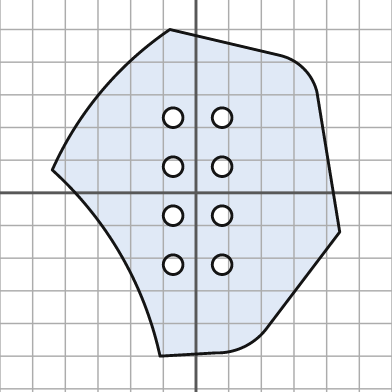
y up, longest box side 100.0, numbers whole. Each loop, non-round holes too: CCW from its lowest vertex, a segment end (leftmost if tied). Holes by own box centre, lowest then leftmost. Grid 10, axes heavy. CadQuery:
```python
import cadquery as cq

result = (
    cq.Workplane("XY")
    .moveTo(-11.0, -50.0)
    .lineTo(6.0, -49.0)
    .threePointArc((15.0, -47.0), (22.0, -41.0))
    .lineTo(44.0, -12.0)
    .lineTo(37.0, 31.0)
    .threePointArc((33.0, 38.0), (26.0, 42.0))
    .lineTo(-8.0, 50.0)
    .threePointArc((-29.0, 31.0), (-44.0, 7.0))
    .threePointArc((-23.0, -19.0), (-11.0, -50.0))
    .close()
    .moveTo(-7.0, -22.0)
    .circle(3.0)
    .moveTo(8.0, -22.0)
    .circle(3.0)
    .moveTo(-7.0, -7.0)
    .circle(3.0)
    .moveTo(8.0, -7.0)
    .circle(3.0)
    .moveTo(-7.0, 8.0)
    .circle(3.0)
    .moveTo(8.0, 8.0)
    .circle(3.0)
    .moveTo(-7.0, 23.0)
    .circle(3.0)
    .moveTo(8.0, 23.0)
    .circle(3.0)
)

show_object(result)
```